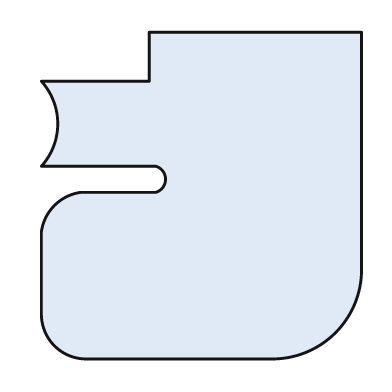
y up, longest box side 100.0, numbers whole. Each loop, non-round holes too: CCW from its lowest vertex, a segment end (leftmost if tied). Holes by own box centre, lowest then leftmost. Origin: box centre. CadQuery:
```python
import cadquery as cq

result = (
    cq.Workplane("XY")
    .moveTo(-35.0, -50.0)
    .lineTo(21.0, -50.0)
    .threePointArc((41.0, -42.0), (49.0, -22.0))
    .lineTo(49.0, 50.0)
    .lineTo(-16.0, 50.0)
    .lineTo(-16.0, 35.0)
    .lineTo(-49.0, 35.0)
    .threePointArc((-44.0, 22.0), (-49.0, 9.0))
    .lineTo(-14.0, 9.0)
    .threePointArc((-11.0, 5.0), (-14.0, 1.0))
    .lineTo(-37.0, 1.0)
    .threePointArc((-45.0, -3.0), (-49.0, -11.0))
    .lineTo(-49.0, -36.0)
    .threePointArc((-45.0, -46.0), (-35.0, -50.0))
    .close()
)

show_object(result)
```